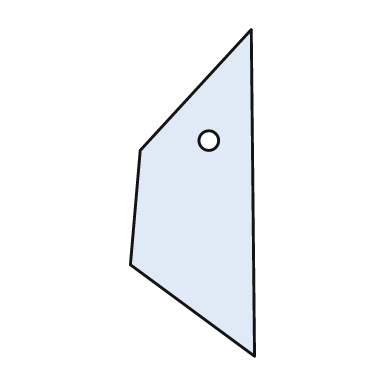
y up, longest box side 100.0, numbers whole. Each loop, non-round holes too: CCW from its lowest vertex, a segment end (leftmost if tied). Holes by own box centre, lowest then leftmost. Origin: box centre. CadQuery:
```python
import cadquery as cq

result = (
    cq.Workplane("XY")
    .moveTo(19.0, -50.0)
    .lineTo(18.0, 50.0)
    .lineTo(-16.0, 13.0)
    .lineTo(-19.0, -22.0)
    .close()
    .moveTo(5.0, 16.0)
    .circle(3.0)
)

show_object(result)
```